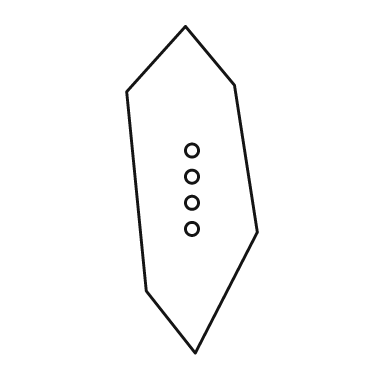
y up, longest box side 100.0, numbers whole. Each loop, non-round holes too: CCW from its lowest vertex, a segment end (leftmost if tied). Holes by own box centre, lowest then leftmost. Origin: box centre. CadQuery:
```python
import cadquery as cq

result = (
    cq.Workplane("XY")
    .moveTo(1.0, -50.0)
    .lineTo(20.0, -13.0)
    .lineTo(13.0, 32.0)
    .lineTo(-2.0, 50.0)
    .lineTo(-20.0, 30.0)
    .lineTo(-14.0, -31.0)
    .close()
    .moveTo(0.0, -12.0)
    .circle(2.0)
    .moveTo(0.0, -4.0)
    .circle(2.0)
    .moveTo(0.0, 4.0)
    .circle(2.0)
    .moveTo(0.0, 12.0)
    .circle(2.0)
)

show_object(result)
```